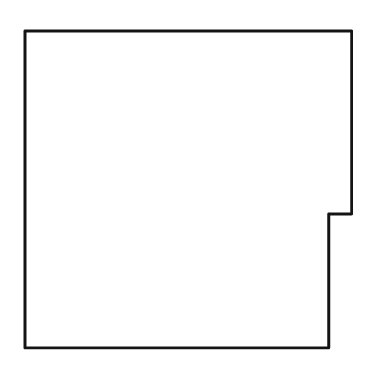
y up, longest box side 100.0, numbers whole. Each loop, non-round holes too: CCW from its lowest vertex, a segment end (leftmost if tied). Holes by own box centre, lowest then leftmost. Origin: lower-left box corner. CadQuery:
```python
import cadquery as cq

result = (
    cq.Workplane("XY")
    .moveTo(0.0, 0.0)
    .lineTo(93.0, 0.0)
    .lineTo(93.0, 41.0)
    .lineTo(100.0, 41.0)
    .lineTo(100.0, 97.0)
    .lineTo(0.0, 97.0)
    .close()
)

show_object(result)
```